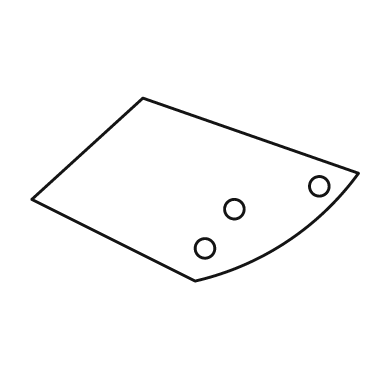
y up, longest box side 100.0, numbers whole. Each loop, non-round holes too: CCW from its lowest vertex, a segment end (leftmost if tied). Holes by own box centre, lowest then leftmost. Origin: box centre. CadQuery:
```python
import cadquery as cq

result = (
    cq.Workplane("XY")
    .moveTo(0.0, -28.0)
    .threePointArc((28.0, -16.0), (50.0, 5.0))
    .lineTo(-16.0, 28.0)
    .lineTo(-50.0, -3.0)
    .close()
    .moveTo(3.0, -18.0)
    .circle(3.0)
    .moveTo(12.0, -6.0)
    .circle(3.0)
    .moveTo(38.0, 1.0)
    .circle(3.0)
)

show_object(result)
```